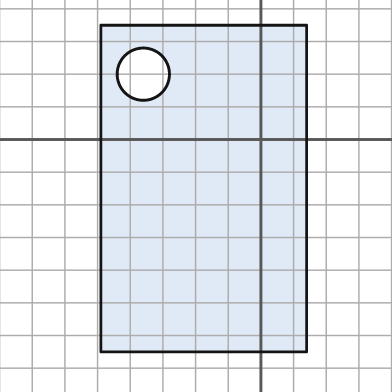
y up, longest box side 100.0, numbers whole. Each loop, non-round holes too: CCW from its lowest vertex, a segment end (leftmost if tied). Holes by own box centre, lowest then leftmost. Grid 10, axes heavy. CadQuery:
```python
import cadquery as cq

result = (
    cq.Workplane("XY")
    .moveTo(-49.0, -65.0)
    .lineTo(14.0, -65.0)
    .lineTo(14.0, 35.0)
    .lineTo(-49.0, 35.0)
    .close()
    .moveTo(-36.0, 20.0)
    .circle(8.0)
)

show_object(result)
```